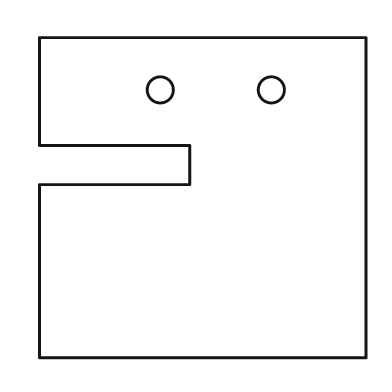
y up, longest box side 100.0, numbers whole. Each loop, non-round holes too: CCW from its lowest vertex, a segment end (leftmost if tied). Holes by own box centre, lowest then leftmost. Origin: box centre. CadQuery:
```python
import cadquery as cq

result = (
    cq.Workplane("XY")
    .moveTo(-50.0, -49.0)
    .lineTo(50.0, -49.0)
    .lineTo(50.0, 49.0)
    .lineTo(-50.0, 49.0)
    .lineTo(-50.0, 16.0)
    .lineTo(-4.0, 16.0)
    .lineTo(-4.0, 4.0)
    .lineTo(-50.0, 4.0)
    .close()
    .moveTo(-13.0, 33.0)
    .circle(4.0)
    .moveTo(21.0, 33.0)
    .circle(4.0)
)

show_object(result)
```